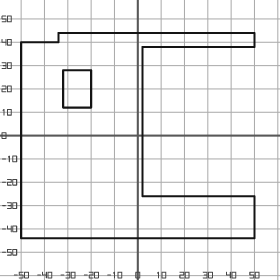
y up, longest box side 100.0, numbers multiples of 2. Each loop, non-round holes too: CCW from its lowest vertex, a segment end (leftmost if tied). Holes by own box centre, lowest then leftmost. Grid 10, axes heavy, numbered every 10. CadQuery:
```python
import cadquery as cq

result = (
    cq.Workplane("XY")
    .moveTo(-50.0, -44.0)
    .lineTo(50.0, -44.0)
    .lineTo(50.0, -26.0)
    .lineTo(2.0, -26.0)
    .lineTo(2.0, 38.0)
    .lineTo(50.0, 38.0)
    .lineTo(50.0, 44.0)
    .lineTo(-34.0, 44.0)
    .lineTo(-34.0, 40.0)
    .lineTo(-50.0, 40.0)
    .close()
    .moveTo(-32.0, 12.0)
    .lineTo(-20.0, 12.0)
    .lineTo(-20.0, 28.0)
    .lineTo(-32.0, 28.0)
    .close()
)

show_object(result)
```